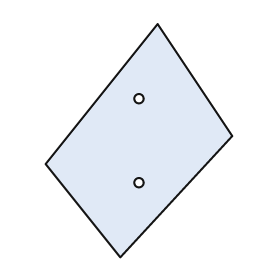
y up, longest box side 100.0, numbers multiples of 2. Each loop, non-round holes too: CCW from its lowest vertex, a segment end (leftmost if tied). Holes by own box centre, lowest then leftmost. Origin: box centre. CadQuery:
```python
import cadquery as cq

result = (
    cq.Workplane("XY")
    .moveTo(-8.0, -50.0)
    .lineTo(40.0, 2.0)
    .lineTo(8.0, 50.0)
    .lineTo(-40.0, -10.0)
    .close()
    .moveTo(0.0, -18.0)
    .circle(2.0)
    .moveTo(0.0, 18.0)
    .circle(2.0)
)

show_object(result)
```